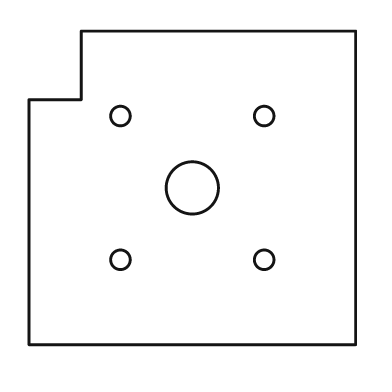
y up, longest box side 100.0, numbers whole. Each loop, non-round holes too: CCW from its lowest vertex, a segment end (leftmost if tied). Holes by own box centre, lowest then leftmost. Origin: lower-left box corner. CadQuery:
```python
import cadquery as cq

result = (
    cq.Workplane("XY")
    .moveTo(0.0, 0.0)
    .lineTo(100.0, 0.0)
    .lineTo(100.0, 96.0)
    .lineTo(16.0, 96.0)
    .lineTo(16.0, 75.0)
    .lineTo(0.0, 75.0)
    .close()
    .moveTo(28.0, 26.0)
    .circle(3.0)
    .moveTo(72.0, 26.0)
    .circle(3.0)
    .moveTo(50.0, 48.0)
    .circle(8.0)
    .moveTo(28.0, 70.0)
    .circle(3.0)
    .moveTo(72.0, 70.0)
    .circle(3.0)
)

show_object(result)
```